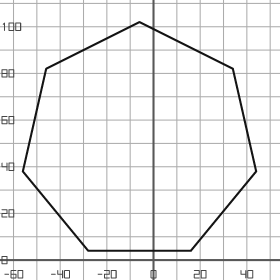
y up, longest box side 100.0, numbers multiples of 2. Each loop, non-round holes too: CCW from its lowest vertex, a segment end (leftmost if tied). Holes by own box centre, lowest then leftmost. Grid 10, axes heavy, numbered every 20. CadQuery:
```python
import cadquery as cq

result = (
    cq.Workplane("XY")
    .moveTo(-28.0, 4.0)
    .lineTo(16.0, 4.0)
    .lineTo(44.0, 38.0)
    .lineTo(34.0, 82.0)
    .lineTo(-6.0, 102.0)
    .lineTo(-46.0, 82.0)
    .lineTo(-56.0, 38.0)
    .close()
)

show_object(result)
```